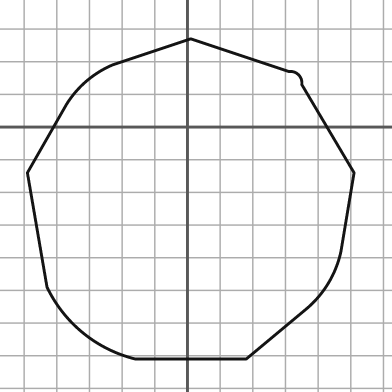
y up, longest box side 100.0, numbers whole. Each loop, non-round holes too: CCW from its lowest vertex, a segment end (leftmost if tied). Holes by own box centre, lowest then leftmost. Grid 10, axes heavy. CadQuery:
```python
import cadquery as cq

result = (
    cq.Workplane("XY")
    .moveTo(-16.0, -71.0)
    .lineTo(18.0, -71.0)
    .lineTo(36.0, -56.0)
    .threePointArc((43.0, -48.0), (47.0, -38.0))
    .lineTo(51.0, -14.0)
    .lineTo(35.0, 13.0)
    .threePointArc((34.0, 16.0), (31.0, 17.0))
    .lineTo(1.0, 27.0)
    .lineTo(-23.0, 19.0)
    .threePointArc((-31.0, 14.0), (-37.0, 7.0))
    .lineTo(-49.0, -14.0)
    .lineTo(-43.0, -49.0)
    .threePointArc((-32.0, -63.0), (-16.0, -71.0))
    .close()
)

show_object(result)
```